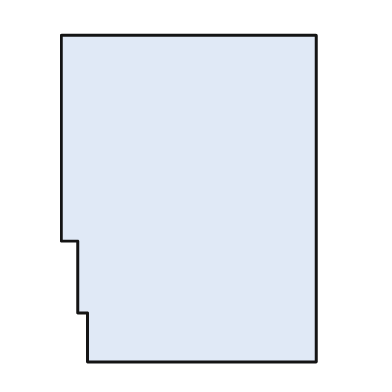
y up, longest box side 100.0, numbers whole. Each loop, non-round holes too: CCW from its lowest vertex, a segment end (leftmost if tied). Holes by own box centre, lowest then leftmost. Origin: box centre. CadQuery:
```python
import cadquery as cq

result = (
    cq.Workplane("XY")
    .moveTo(-31.0, -50.0)
    .lineTo(39.0, -50.0)
    .lineTo(39.0, 50.0)
    .lineTo(-39.0, 50.0)
    .lineTo(-39.0, -13.0)
    .lineTo(-34.0, -13.0)
    .lineTo(-34.0, -35.0)
    .lineTo(-31.0, -35.0)
    .close()
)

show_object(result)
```